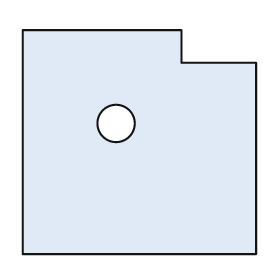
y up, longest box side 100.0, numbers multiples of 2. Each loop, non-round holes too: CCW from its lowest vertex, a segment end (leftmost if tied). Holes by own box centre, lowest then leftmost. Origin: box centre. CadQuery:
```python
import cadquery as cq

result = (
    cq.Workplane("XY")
    .moveTo(-50.0, -48.0)
    .lineTo(50.0, -48.0)
    .lineTo(50.0, 34.0)
    .lineTo(18.0, 34.0)
    .lineTo(18.0, 48.0)
    .lineTo(-50.0, 48.0)
    .close()
    .moveTo(-10.0, 8.0)
    .circle(8.0)
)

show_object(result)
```